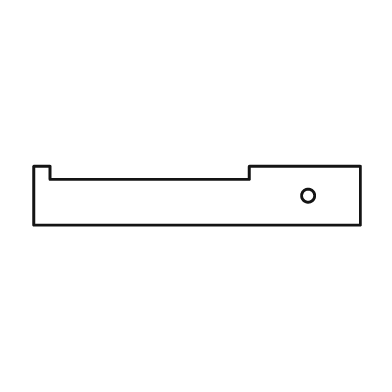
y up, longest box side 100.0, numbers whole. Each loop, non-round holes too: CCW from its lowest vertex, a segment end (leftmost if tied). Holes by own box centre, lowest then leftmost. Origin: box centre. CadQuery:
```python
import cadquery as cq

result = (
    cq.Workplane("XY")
    .moveTo(-50.0, -9.0)
    .lineTo(50.0, -9.0)
    .lineTo(50.0, 9.0)
    .lineTo(16.0, 9.0)
    .lineTo(16.0, 5.0)
    .lineTo(-45.0, 5.0)
    .lineTo(-45.0, 9.0)
    .lineTo(-50.0, 9.0)
    .close()
    .moveTo(34.0, 0.0)
    .circle(2.0)
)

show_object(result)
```